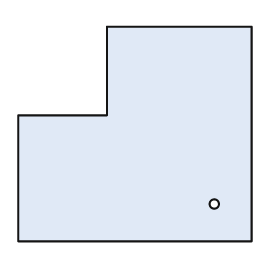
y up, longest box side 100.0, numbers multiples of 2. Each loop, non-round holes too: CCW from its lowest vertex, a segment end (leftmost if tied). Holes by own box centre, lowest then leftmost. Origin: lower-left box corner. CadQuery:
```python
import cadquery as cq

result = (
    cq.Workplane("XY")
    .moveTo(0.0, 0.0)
    .lineTo(100.0, 0.0)
    .lineTo(100.0, 92.0)
    .lineTo(38.0, 92.0)
    .lineTo(38.0, 54.0)
    .lineTo(0.0, 54.0)
    .close()
    .moveTo(84.0, 16.0)
    .circle(2.0)
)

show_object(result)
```